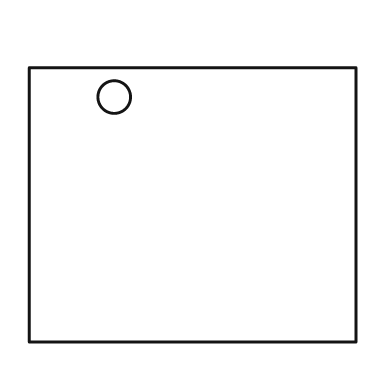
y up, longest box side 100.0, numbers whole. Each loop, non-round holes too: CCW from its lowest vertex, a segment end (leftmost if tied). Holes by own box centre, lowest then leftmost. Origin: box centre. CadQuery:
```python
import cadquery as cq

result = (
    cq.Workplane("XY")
    .moveTo(-50.0, -42.0)
    .lineTo(50.0, -42.0)
    .lineTo(50.0, 42.0)
    .lineTo(-50.0, 42.0)
    .close()
    .moveTo(-24.0, 33.0)
    .circle(5.0)
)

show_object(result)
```